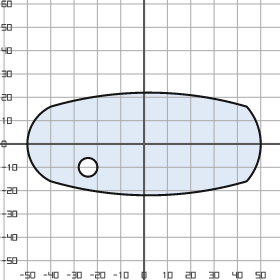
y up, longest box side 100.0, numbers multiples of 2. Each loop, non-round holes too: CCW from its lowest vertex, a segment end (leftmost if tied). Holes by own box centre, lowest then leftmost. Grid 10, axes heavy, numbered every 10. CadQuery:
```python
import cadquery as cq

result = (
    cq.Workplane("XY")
    .moveTo(-40.0, -16.0)
    .threePointArc((2.0, -22.0), (44.0, -16.0))
    .threePointArc((50.0, 0.0), (44.0, 16.0))
    .threePointArc((2.0, 22.0), (-40.0, 16.0))
    .threePointArc((-50.0, 0.0), (-40.0, -16.0))
    .close()
    .moveTo(-24.0, -10.0)
    .circle(4.0)
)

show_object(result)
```